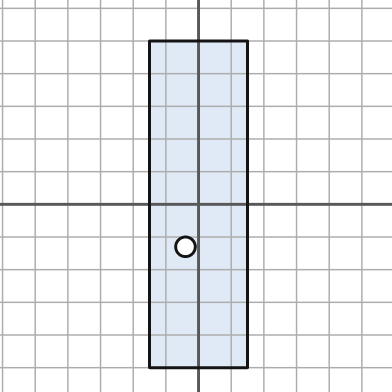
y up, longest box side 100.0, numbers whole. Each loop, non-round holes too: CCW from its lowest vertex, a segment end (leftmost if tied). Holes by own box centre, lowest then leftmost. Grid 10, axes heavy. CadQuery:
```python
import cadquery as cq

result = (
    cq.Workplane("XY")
    .moveTo(-15.0, -50.0)
    .lineTo(15.0, -50.0)
    .lineTo(15.0, 50.0)
    .lineTo(-15.0, 50.0)
    .close()
    .moveTo(-4.0, -13.0)
    .circle(3.0)
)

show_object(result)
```